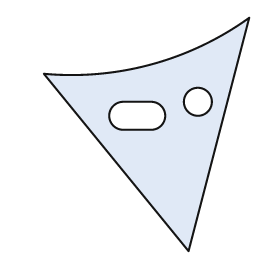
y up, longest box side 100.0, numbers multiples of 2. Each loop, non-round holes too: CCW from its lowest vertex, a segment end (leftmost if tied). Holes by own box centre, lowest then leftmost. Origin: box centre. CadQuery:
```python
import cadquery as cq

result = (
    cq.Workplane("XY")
    .moveTo(18.0, -50.0)
    .lineTo(44.0, 50.0)
    .threePointArc((2.0, 30.0), (-44.0, 26.0))
    .close()
    .moveTo(-10.0, 2.0)
    .lineTo(2.0, 2.0)
    .threePointArc((8.0, 8.0), (2.0, 14.0))
    .lineTo(-10.0, 14.0)
    .threePointArc((-16.0, 8.0), (-10.0, 2.0))
    .close()
    .moveTo(22.0, 14.0)
    .circle(6.0)
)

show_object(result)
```